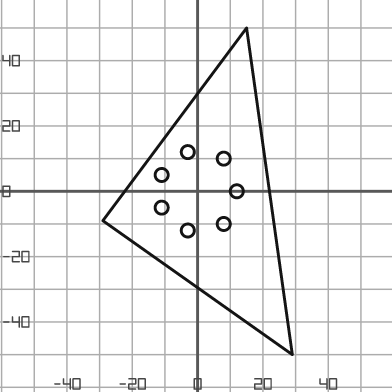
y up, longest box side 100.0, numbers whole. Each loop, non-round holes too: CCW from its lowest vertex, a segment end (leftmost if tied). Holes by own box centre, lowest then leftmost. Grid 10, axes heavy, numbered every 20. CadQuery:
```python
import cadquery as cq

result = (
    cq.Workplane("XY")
    .moveTo(29.0, -50.0)
    .lineTo(15.0, 50.0)
    .lineTo(-29.0, -9.0)
    .close()
    .moveTo(-3.0, -12.0)
    .circle(2.0)
    .moveTo(8.0, -10.0)
    .circle(2.0)
    .moveTo(-11.0, -5.0)
    .circle(2.0)
    .moveTo(12.0, 0.0)
    .circle(2.0)
    .moveTo(-11.0, 5.0)
    .circle(2.0)
    .moveTo(8.0, 10.0)
    .circle(2.0)
    .moveTo(-3.0, 12.0)
    .circle(2.0)
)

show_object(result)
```